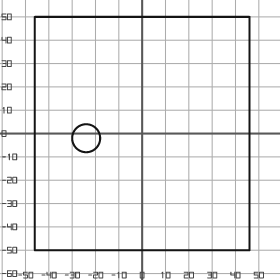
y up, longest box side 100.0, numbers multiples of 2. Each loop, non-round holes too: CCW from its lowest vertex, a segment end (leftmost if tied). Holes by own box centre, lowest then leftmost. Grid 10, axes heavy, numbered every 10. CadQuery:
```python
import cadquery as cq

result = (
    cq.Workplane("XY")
    .moveTo(-46.0, -50.0)
    .lineTo(46.0, -50.0)
    .lineTo(46.0, 50.0)
    .lineTo(-46.0, 50.0)
    .close()
    .moveTo(-24.0, -2.0)
    .circle(6.0)
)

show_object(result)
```